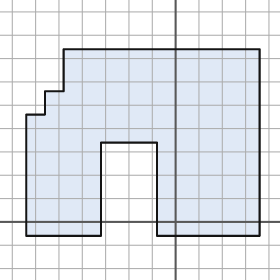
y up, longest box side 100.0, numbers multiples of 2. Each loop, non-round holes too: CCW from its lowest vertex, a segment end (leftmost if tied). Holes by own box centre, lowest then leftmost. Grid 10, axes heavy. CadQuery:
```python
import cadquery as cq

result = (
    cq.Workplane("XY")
    .moveTo(-64.0, -6.0)
    .lineTo(-32.0, -6.0)
    .lineTo(-32.0, 34.0)
    .lineTo(-8.0, 34.0)
    .lineTo(-8.0, -6.0)
    .lineTo(36.0, -6.0)
    .lineTo(36.0, 74.0)
    .lineTo(-48.0, 74.0)
    .lineTo(-48.0, 56.0)
    .lineTo(-56.0, 56.0)
    .lineTo(-56.0, 46.0)
    .lineTo(-64.0, 46.0)
    .close()
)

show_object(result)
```